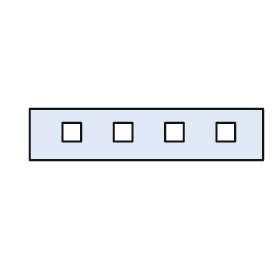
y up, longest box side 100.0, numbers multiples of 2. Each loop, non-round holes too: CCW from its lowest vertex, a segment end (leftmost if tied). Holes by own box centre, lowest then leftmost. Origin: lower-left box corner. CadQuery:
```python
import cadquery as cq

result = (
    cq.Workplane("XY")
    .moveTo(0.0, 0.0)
    .lineTo(100.0, 0.0)
    .lineTo(100.0, 22.0)
    .lineTo(0.0, 22.0)
    .close()
    .moveTo(14.0, 8.0)
    .lineTo(22.0, 8.0)
    .lineTo(22.0, 16.0)
    .lineTo(14.0, 16.0)
    .close()
    .moveTo(36.0, 8.0)
    .lineTo(44.0, 8.0)
    .lineTo(44.0, 16.0)
    .lineTo(36.0, 16.0)
    .close()
    .moveTo(58.0, 8.0)
    .lineTo(66.0, 8.0)
    .lineTo(66.0, 16.0)
    .lineTo(58.0, 16.0)
    .close()
    .moveTo(80.0, 8.0)
    .lineTo(88.0, 8.0)
    .lineTo(88.0, 16.0)
    .lineTo(80.0, 16.0)
    .close()
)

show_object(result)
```